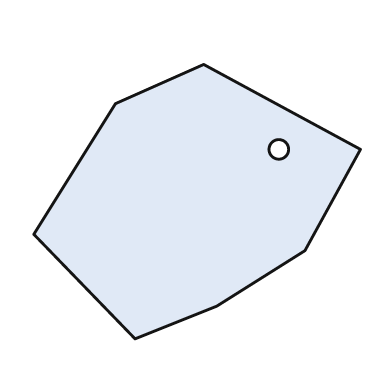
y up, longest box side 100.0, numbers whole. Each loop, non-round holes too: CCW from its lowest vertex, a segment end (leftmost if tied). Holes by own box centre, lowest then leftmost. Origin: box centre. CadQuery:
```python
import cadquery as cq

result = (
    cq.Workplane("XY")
    .moveTo(-19.0, -42.0)
    .lineTo(6.0, -32.0)
    .lineTo(33.0, -15.0)
    .lineTo(50.0, 16.0)
    .lineTo(2.0, 42.0)
    .lineTo(-25.0, 30.0)
    .lineTo(-50.0, -10.0)
    .close()
    .moveTo(25.0, 16.0)
    .circle(3.0)
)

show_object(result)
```